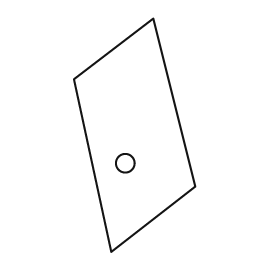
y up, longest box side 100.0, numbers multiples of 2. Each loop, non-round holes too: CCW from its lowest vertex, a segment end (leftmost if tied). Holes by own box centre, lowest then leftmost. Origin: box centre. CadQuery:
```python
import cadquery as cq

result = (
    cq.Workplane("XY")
    .moveTo(-10.0, -50.0)
    .lineTo(26.0, -22.0)
    .lineTo(8.0, 50.0)
    .lineTo(-26.0, 24.0)
    .close()
    .moveTo(-4.0, -12.0)
    .circle(4.0)
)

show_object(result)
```